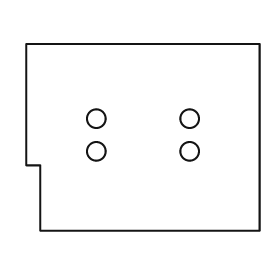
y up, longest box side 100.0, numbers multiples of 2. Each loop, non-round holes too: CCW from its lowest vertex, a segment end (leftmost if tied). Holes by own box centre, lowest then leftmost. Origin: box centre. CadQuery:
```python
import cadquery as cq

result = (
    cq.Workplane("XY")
    .moveTo(-44.0, -40.0)
    .lineTo(50.0, -40.0)
    .lineTo(50.0, 40.0)
    .lineTo(-50.0, 40.0)
    .lineTo(-50.0, -12.0)
    .lineTo(-44.0, -12.0)
    .close()
    .moveTo(-20.0, -6.0)
    .circle(4.0)
    .moveTo(20.0, -6.0)
    .circle(4.0)
    .moveTo(-20.0, 8.0)
    .circle(4.0)
    .moveTo(20.0, 8.0)
    .circle(4.0)
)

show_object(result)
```